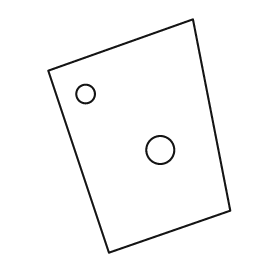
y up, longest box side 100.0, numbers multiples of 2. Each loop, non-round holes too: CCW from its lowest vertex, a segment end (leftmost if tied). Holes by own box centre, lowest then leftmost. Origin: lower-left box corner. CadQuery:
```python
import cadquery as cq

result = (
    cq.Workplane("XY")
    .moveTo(26.0, 0.0)
    .lineTo(78.0, 18.0)
    .lineTo(62.0, 100.0)
    .lineTo(0.0, 78.0)
    .close()
    .moveTo(48.0, 44.0)
    .circle(6.0)
    .moveTo(16.0, 68.0)
    .circle(4.0)
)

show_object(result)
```